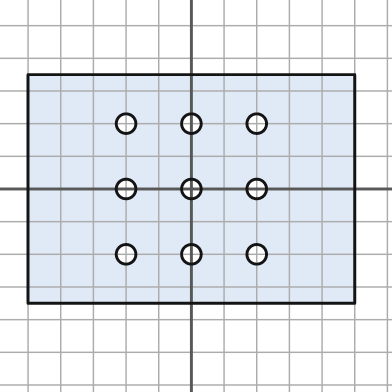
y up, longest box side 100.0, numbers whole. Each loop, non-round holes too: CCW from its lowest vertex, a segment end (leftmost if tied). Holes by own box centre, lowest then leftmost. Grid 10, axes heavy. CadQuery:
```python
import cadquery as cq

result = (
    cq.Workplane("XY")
    .moveTo(-50.0, -35.0)
    .lineTo(50.0, -35.0)
    .lineTo(50.0, 35.0)
    .lineTo(-50.0, 35.0)
    .close()
    .moveTo(-20.0, -20.0)
    .circle(3.0)
    .moveTo(0.0, -20.0)
    .circle(3.0)
    .moveTo(20.0, -20.0)
    .circle(3.0)
    .moveTo(-20.0, 0.0)
    .circle(3.0)
    .moveTo(0.0, 0.0)
    .circle(3.0)
    .moveTo(20.0, 0.0)
    .circle(3.0)
    .moveTo(-20.0, 20.0)
    .circle(3.0)
    .moveTo(0.0, 20.0)
    .circle(3.0)
    .moveTo(20.0, 20.0)
    .circle(3.0)
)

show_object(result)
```